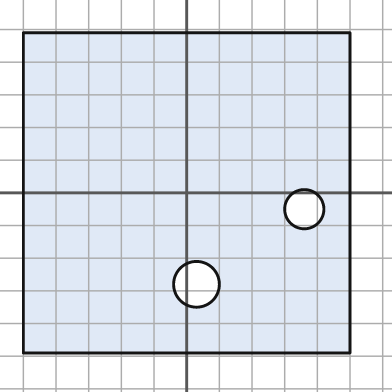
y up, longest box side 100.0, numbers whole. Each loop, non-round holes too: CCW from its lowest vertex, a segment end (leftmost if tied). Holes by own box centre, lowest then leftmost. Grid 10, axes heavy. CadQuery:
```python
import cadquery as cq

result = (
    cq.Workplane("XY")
    .moveTo(-50.0, -49.0)
    .lineTo(50.0, -49.0)
    .lineTo(50.0, 49.0)
    .lineTo(-50.0, 49.0)
    .close()
    .moveTo(3.0, -28.0)
    .circle(7.0)
    .moveTo(36.0, -5.0)
    .circle(6.0)
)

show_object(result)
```